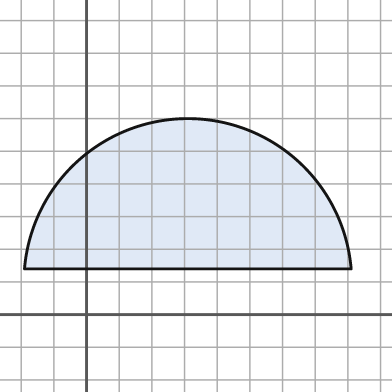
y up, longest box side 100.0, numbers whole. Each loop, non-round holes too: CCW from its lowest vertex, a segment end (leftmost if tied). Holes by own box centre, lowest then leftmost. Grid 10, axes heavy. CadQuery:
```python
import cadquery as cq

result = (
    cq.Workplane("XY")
    .moveTo(-19.0, 14.0)
    .lineTo(81.0, 14.0)
    .threePointArc((31.0, 60.0), (-19.0, 14.0))
    .close()
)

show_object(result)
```